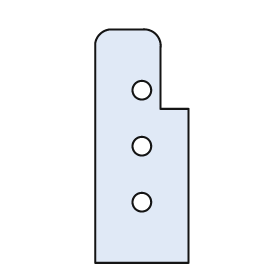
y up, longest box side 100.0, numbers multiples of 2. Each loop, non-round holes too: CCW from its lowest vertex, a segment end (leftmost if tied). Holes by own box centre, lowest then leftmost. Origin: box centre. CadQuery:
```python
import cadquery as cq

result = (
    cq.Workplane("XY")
    .moveTo(-20.0, -50.0)
    .lineTo(20.0, -50.0)
    .lineTo(20.0, 16.0)
    .lineTo(8.0, 16.0)
    .lineTo(8.0, 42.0)
    .threePointArc((6.0, 48.0), (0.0, 50.0))
    .lineTo(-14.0, 50.0)
    .threePointArc((-18.0, 48.0), (-20.0, 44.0))
    .close()
    .moveTo(0.0, -24.0)
    .circle(4.0)
    .moveTo(0.0, 0.0)
    .circle(4.0)
    .moveTo(0.0, 24.0)
    .circle(4.0)
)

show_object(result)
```